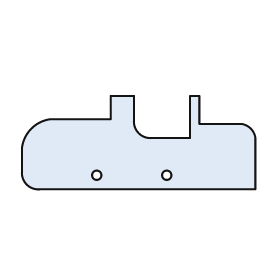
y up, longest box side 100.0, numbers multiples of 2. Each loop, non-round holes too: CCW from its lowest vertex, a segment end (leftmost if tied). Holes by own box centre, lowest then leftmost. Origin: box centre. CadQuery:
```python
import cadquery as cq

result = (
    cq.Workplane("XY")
    .moveTo(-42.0, -20.0)
    .lineTo(50.0, -20.0)
    .lineTo(50.0, 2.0)
    .threePointArc((48.0, 6.0), (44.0, 8.0))
    .lineTo(26.0, 8.0)
    .lineTo(26.0, 20.0)
    .lineTo(22.0, 20.0)
    .lineTo(22.0, 2.0)
    .lineTo(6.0, 2.0)
    .threePointArc((0.0, 4.0), (-2.0, 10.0))
    .lineTo(-2.0, 20.0)
    .lineTo(-12.0, 20.0)
    .lineTo(-12.0, 10.0)
    .lineTo(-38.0, 10.0)
    .threePointArc((-46.0, 6.0), (-50.0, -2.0))
    .lineTo(-50.0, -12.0)
    .threePointArc((-48.0, -18.0), (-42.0, -20.0))
    .close()
    .moveTo(-18.0, -14.0)
    .circle(2.0)
    .moveTo(12.0, -14.0)
    .circle(2.0)
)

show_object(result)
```